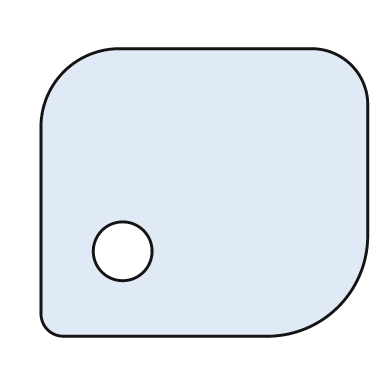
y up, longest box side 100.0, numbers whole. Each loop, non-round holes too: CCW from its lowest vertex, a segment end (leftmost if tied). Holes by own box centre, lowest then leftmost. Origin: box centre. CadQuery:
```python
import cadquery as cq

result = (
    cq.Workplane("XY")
    .moveTo(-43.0, -44.0)
    .lineTo(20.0, -44.0)
    .threePointArc((41.0, -35.0), (50.0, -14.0))
    .lineTo(50.0, 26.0)
    .threePointArc((45.0, 39.0), (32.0, 44.0))
    .lineTo(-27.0, 44.0)
    .threePointArc((-43.0, 37.0), (-50.0, 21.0))
    .lineTo(-50.0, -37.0)
    .threePointArc((-48.0, -42.0), (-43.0, -44.0))
    .close()
    .moveTo(-25.0, -18.0)
    .circle(9.0)
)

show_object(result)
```